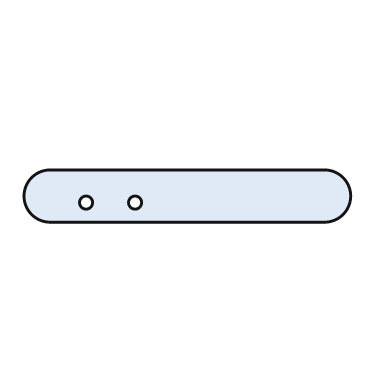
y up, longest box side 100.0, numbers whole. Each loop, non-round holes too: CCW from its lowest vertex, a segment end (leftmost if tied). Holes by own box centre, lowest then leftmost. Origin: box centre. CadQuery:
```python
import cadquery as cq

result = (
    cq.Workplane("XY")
    .moveTo(-42.0, -8.0)
    .lineTo(42.0, -8.0)
    .threePointArc((50.0, 0.0), (42.0, 8.0))
    .lineTo(-42.0, 8.0)
    .threePointArc((-50.0, 0.0), (-42.0, -8.0))
    .close()
    .moveTo(-31.0, -2.0)
    .circle(2.0)
    .moveTo(-16.0, -2.0)
    .circle(2.0)
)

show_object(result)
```